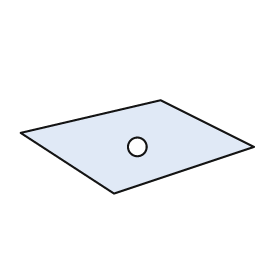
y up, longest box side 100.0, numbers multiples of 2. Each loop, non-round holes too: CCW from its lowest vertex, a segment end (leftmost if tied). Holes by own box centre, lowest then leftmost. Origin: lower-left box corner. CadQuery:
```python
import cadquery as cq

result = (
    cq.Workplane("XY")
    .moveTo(40.0, 0.0)
    .lineTo(100.0, 20.0)
    .lineTo(60.0, 40.0)
    .lineTo(0.0, 26.0)
    .close()
    .moveTo(50.0, 20.0)
    .circle(4.0)
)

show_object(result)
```